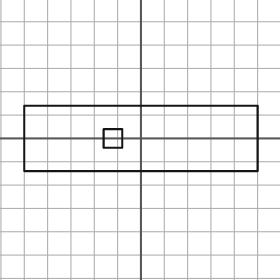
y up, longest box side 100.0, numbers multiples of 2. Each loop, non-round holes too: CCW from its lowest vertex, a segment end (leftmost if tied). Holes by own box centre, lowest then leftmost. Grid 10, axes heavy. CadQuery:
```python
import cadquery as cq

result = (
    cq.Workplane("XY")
    .moveTo(-50.0, -14.0)
    .lineTo(50.0, -14.0)
    .lineTo(50.0, 14.0)
    .lineTo(-50.0, 14.0)
    .close()
    .moveTo(-16.0, -4.0)
    .lineTo(-8.0, -4.0)
    .lineTo(-8.0, 4.0)
    .lineTo(-16.0, 4.0)
    .close()
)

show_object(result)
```